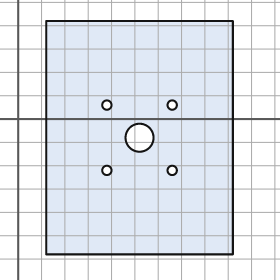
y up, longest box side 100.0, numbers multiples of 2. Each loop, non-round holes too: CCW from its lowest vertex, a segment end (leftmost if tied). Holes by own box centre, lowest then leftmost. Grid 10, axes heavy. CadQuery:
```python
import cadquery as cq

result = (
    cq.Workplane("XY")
    .moveTo(12.0, -58.0)
    .lineTo(92.0, -58.0)
    .lineTo(92.0, 42.0)
    .lineTo(12.0, 42.0)
    .close()
    .moveTo(38.0, -22.0)
    .circle(2.0)
    .moveTo(66.0, -22.0)
    .circle(2.0)
    .moveTo(52.0, -8.0)
    .circle(6.0)
    .moveTo(38.0, 6.0)
    .circle(2.0)
    .moveTo(66.0, 6.0)
    .circle(2.0)
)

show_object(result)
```